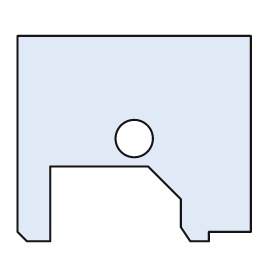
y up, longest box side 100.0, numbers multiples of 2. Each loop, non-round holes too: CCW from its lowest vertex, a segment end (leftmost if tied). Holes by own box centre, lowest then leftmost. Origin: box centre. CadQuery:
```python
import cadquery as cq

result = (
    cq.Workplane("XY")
    .moveTo(-46.0, -44.0)
    .lineTo(-36.0, -44.0)
    .lineTo(-36.0, -12.0)
    .lineTo(6.0, -12.0)
    .lineTo(20.0, -26.0)
    .lineTo(20.0, -38.0)
    .lineTo(24.0, -44.0)
    .lineTo(32.0, -44.0)
    .lineTo(32.0, -40.0)
    .lineTo(50.0, -40.0)
    .lineTo(50.0, 44.0)
    .lineTo(-50.0, 44.0)
    .lineTo(-50.0, -40.0)
    .close()
    .moveTo(0.0, 0.0)
    .circle(8.0)
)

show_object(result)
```